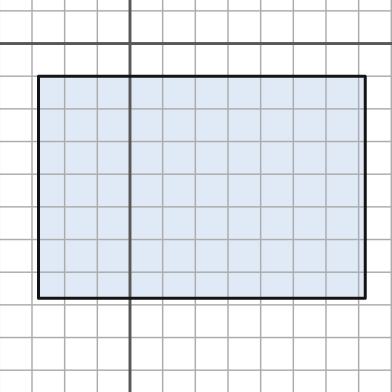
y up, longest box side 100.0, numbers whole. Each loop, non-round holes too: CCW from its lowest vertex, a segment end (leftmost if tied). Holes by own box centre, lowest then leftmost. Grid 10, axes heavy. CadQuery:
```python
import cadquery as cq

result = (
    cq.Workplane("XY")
    .moveTo(-28.0, -78.0)
    .lineTo(72.0, -78.0)
    .lineTo(72.0, -10.0)
    .lineTo(-28.0, -10.0)
    .close()
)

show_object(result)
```